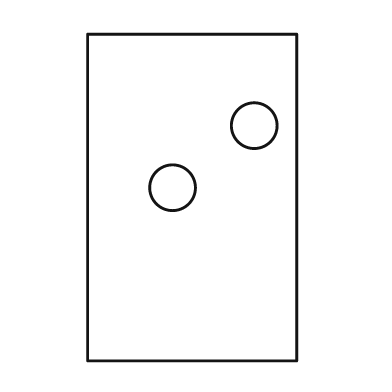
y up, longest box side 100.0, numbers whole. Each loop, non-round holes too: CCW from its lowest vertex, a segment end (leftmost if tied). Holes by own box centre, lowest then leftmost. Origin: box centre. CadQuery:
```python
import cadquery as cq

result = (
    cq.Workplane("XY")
    .moveTo(-32.0, -50.0)
    .lineTo(32.0, -50.0)
    .lineTo(32.0, 50.0)
    .lineTo(-32.0, 50.0)
    .close()
    .moveTo(-6.0, 3.0)
    .circle(7.0)
    .moveTo(19.0, 22.0)
    .circle(7.0)
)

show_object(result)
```